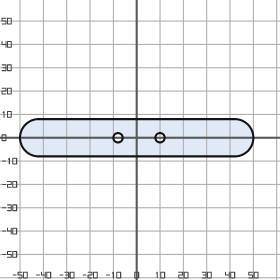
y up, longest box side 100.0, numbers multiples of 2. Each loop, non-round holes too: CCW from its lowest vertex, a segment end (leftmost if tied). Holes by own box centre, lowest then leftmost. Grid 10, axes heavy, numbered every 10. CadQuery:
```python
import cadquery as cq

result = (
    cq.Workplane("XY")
    .moveTo(-42.0, -8.0)
    .lineTo(42.0, -8.0)
    .threePointArc((50.0, 0.0), (42.0, 8.0))
    .lineTo(-42.0, 8.0)
    .threePointArc((-50.0, 0.0), (-42.0, -8.0))
    .close()
    .moveTo(-8.0, 0.0)
    .circle(2.0)
    .moveTo(10.0, 0.0)
    .circle(2.0)
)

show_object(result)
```